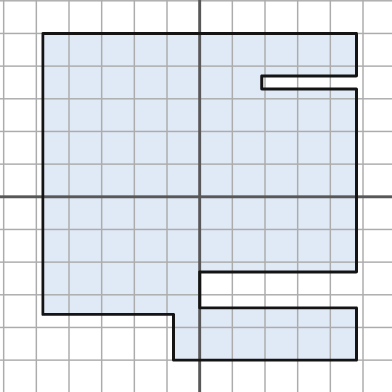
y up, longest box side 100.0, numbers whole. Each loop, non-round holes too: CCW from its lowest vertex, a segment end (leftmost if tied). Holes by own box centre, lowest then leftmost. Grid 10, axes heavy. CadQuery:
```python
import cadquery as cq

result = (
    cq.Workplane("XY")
    .moveTo(-8.0, -50.0)
    .lineTo(48.0, -50.0)
    .lineTo(48.0, -34.0)
    .lineTo(0.0, -34.0)
    .lineTo(0.0, -23.0)
    .lineTo(48.0, -23.0)
    .lineTo(48.0, 33.0)
    .lineTo(19.0, 33.0)
    .lineTo(19.0, 37.0)
    .lineTo(48.0, 37.0)
    .lineTo(48.0, 50.0)
    .lineTo(-48.0, 50.0)
    .lineTo(-48.0, -36.0)
    .lineTo(-8.0, -36.0)
    .close()
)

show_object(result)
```